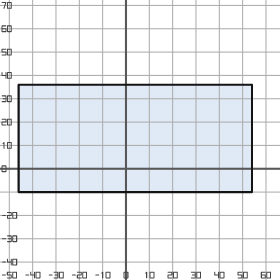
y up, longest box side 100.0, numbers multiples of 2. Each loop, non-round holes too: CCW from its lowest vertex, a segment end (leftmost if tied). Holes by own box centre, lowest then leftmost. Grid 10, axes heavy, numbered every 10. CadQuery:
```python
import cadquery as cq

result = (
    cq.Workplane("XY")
    .moveTo(-46.0, -10.0)
    .lineTo(54.0, -10.0)
    .lineTo(54.0, 36.0)
    .lineTo(-46.0, 36.0)
    .close()
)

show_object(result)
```